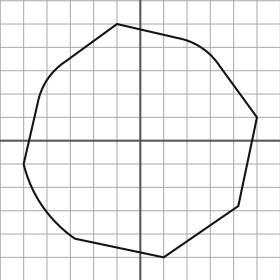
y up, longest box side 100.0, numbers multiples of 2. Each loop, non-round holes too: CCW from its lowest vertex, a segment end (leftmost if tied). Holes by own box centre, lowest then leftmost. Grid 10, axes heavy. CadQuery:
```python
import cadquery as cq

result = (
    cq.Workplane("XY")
    .moveTo(10.0, -50.0)
    .lineTo(42.0, -28.0)
    .lineTo(50.0, 10.0)
    .lineTo(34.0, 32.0)
    .threePointArc((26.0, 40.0), (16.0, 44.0))
    .lineTo(-10.0, 50.0)
    .lineTo(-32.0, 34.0)
    .threePointArc((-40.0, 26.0), (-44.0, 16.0))
    .lineTo(-50.0, -10.0)
    .threePointArc((-42.0, -28.0), (-28.0, -42.0))
    .close()
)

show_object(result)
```